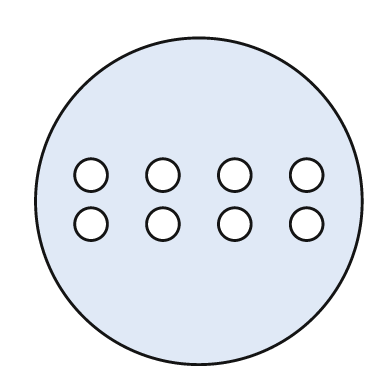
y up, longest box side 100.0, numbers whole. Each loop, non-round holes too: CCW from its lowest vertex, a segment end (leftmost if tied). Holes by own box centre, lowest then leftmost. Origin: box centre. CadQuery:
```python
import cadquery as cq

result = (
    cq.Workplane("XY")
    .moveTo(0.0, 0.0)
    .circle(50.0)
    .moveTo(-33.0, -7.0)
    .circle(5.0)
    .moveTo(-11.0, -7.0)
    .circle(5.0)
    .moveTo(11.0, -7.0)
    .circle(5.0)
    .moveTo(33.0, -7.0)
    .circle(5.0)
    .moveTo(-33.0, 8.0)
    .circle(5.0)
    .moveTo(-11.0, 8.0)
    .circle(5.0)
    .moveTo(11.0, 8.0)
    .circle(5.0)
    .moveTo(33.0, 8.0)
    .circle(5.0)
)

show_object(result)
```